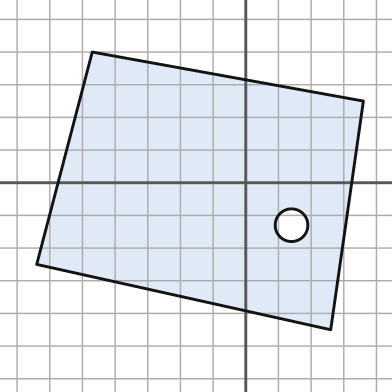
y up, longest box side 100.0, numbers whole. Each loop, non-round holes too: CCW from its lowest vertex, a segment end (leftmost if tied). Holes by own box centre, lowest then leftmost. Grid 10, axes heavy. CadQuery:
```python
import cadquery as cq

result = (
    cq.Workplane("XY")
    .moveTo(26.0, -45.0)
    .lineTo(36.0, 25.0)
    .lineTo(-47.0, 40.0)
    .lineTo(-64.0, -25.0)
    .close()
    .moveTo(14.0, -13.0)
    .circle(5.0)
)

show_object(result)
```